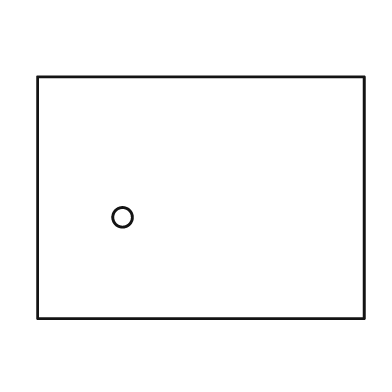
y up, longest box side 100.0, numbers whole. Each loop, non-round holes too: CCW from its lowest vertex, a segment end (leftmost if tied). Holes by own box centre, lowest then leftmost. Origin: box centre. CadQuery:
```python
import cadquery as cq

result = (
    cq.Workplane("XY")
    .moveTo(-50.0, -37.0)
    .lineTo(50.0, -37.0)
    .lineTo(50.0, 37.0)
    .lineTo(-50.0, 37.0)
    .close()
    .moveTo(-24.0, -6.0)
    .circle(3.0)
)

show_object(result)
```